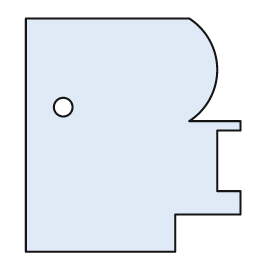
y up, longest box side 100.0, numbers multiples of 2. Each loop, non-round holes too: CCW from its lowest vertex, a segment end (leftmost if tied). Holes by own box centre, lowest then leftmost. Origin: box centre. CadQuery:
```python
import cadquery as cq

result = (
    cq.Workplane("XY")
    .moveTo(-46.0, -50.0)
    .lineTo(18.0, -50.0)
    .lineTo(18.0, -34.0)
    .lineTo(46.0, -34.0)
    .lineTo(46.0, -24.0)
    .lineTo(36.0, -24.0)
    .lineTo(36.0, 2.0)
    .lineTo(46.0, 2.0)
    .lineTo(46.0, 6.0)
    .lineTo(24.0, 6.0)
    .threePointArc((36.0, 28.0), (24.0, 50.0))
    .lineTo(-46.0, 50.0)
    .close()
    .moveTo(-30.0, 12.0)
    .circle(4.0)
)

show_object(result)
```